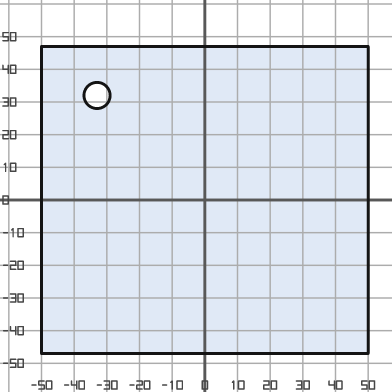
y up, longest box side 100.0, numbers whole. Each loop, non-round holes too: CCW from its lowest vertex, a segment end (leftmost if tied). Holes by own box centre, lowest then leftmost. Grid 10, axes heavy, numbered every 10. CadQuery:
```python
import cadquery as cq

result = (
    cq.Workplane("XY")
    .moveTo(-50.0, -47.0)
    .lineTo(50.0, -47.0)
    .lineTo(50.0, 47.0)
    .lineTo(-50.0, 47.0)
    .close()
    .moveTo(-33.0, 32.0)
    .circle(4.0)
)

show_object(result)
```